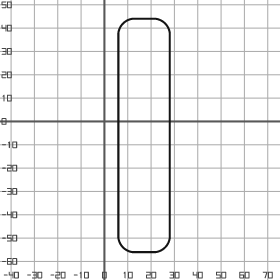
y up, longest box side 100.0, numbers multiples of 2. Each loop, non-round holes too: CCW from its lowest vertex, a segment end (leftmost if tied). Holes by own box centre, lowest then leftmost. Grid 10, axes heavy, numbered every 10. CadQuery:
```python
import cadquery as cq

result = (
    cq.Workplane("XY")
    .moveTo(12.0, -56.0)
    .lineTo(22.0, -56.0)
    .threePointArc((26.0, -54.0), (28.0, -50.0))
    .lineTo(28.0, 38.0)
    .threePointArc((26.0, 42.0), (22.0, 44.0))
    .lineTo(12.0, 44.0)
    .threePointArc((8.0, 42.0), (6.0, 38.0))
    .lineTo(6.0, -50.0)
    .threePointArc((8.0, -54.0), (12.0, -56.0))
    .close()
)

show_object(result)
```